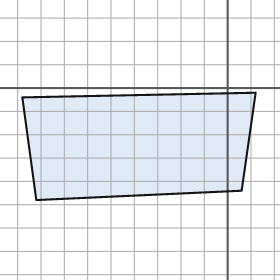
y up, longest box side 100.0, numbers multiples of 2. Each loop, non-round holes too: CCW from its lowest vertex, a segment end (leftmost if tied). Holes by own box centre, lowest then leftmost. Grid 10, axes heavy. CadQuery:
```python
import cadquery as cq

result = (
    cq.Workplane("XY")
    .moveTo(-82.0, -48.0)
    .lineTo(6.0, -44.0)
    .lineTo(12.0, -2.0)
    .lineTo(-88.0, -4.0)
    .close()
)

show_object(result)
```